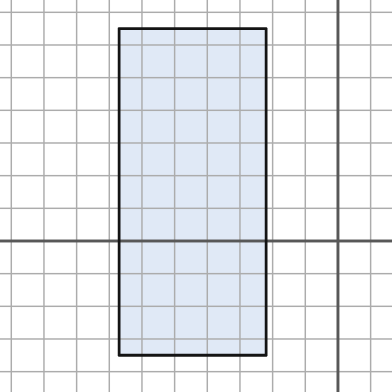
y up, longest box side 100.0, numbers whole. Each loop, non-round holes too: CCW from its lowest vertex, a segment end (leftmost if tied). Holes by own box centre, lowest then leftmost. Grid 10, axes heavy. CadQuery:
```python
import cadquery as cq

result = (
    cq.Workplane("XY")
    .moveTo(-67.0, -35.0)
    .lineTo(-22.0, -35.0)
    .lineTo(-22.0, 65.0)
    .lineTo(-67.0, 65.0)
    .close()
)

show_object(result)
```